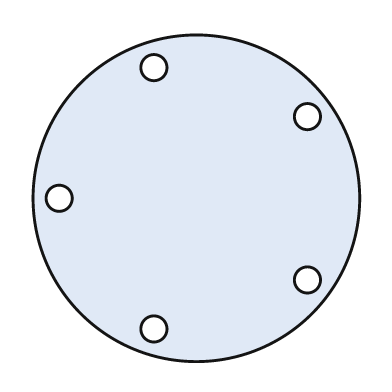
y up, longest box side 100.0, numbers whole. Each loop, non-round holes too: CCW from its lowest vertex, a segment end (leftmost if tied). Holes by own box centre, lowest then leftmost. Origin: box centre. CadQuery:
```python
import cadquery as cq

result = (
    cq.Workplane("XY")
    .moveTo(0.0, 0.0)
    .circle(50.0)
    .moveTo(-13.0, -40.0)
    .circle(4.0)
    .moveTo(34.0, -25.0)
    .circle(4.0)
    .moveTo(-42.0, 0.0)
    .circle(4.0)
    .moveTo(34.0, 25.0)
    .circle(4.0)
    .moveTo(-13.0, 40.0)
    .circle(4.0)
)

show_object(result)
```